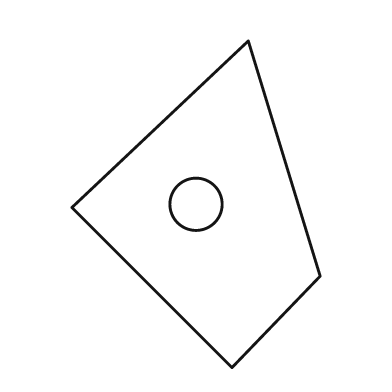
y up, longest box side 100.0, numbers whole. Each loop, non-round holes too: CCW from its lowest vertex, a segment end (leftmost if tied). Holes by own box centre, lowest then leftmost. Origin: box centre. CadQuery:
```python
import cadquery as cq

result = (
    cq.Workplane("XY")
    .moveTo(11.0, -50.0)
    .lineTo(38.0, -22.0)
    .lineTo(16.0, 50.0)
    .lineTo(-38.0, -1.0)
    .close()
    .moveTo(0.0, 0.0)
    .circle(8.0)
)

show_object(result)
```